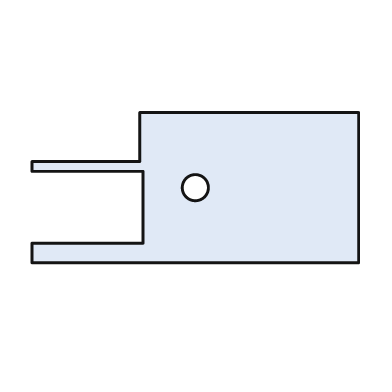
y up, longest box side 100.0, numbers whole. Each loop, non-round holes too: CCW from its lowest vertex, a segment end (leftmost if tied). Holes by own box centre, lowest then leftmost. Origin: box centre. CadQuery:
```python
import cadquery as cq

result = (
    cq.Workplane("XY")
    .moveTo(-50.0, -23.0)
    .lineTo(50.0, -23.0)
    .lineTo(50.0, 23.0)
    .lineTo(-17.0, 23.0)
    .lineTo(-17.0, 8.0)
    .lineTo(-50.0, 8.0)
    .lineTo(-50.0, 5.0)
    .lineTo(-16.0, 5.0)
    .lineTo(-16.0, -17.0)
    .lineTo(-50.0, -17.0)
    .close()
    .moveTo(0.0, 0.0)
    .circle(4.0)
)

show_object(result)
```